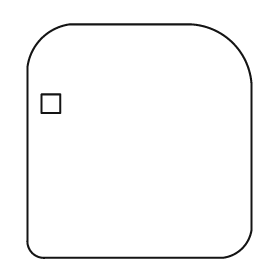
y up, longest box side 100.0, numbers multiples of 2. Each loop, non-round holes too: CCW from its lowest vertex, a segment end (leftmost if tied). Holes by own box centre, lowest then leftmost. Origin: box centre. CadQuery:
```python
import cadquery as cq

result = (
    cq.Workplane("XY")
    .moveTo(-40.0, -50.0)
    .lineTo(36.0, -50.0)
    .threePointArc((44.0, -46.0), (48.0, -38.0))
    .lineTo(48.0, 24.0)
    .threePointArc((40.0, 42.0), (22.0, 50.0))
    .lineTo(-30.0, 50.0)
    .threePointArc((-42.0, 44.0), (-48.0, 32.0))
    .lineTo(-48.0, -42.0)
    .threePointArc((-46.0, -48.0), (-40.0, -50.0))
    .close()
    .moveTo(-42.0, 12.0)
    .lineTo(-34.0, 12.0)
    .lineTo(-34.0, 20.0)
    .lineTo(-42.0, 20.0)
    .close()
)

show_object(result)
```